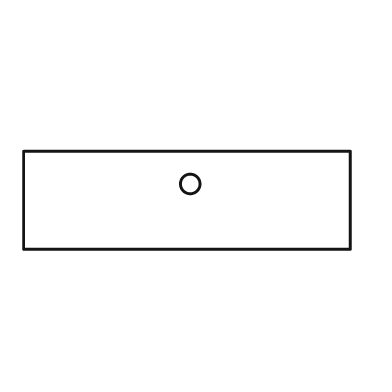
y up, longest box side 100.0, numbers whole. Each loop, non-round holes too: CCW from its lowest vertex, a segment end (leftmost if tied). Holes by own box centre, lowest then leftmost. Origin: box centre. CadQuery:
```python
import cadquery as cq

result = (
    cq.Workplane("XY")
    .moveTo(-50.0, -15.0)
    .lineTo(50.0, -15.0)
    .lineTo(50.0, 15.0)
    .lineTo(-50.0, 15.0)
    .close()
    .moveTo(1.0, 5.0)
    .circle(3.0)
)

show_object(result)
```